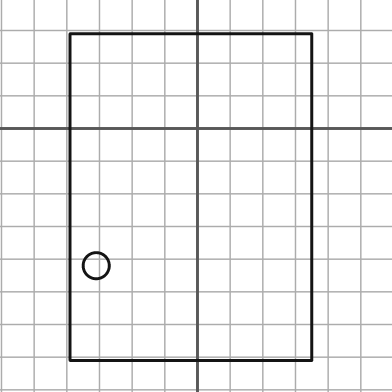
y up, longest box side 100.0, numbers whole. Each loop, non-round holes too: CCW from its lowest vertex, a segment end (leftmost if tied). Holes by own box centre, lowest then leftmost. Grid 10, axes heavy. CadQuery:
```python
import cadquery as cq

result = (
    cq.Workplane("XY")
    .moveTo(-39.0, -71.0)
    .lineTo(35.0, -71.0)
    .lineTo(35.0, 29.0)
    .lineTo(-39.0, 29.0)
    .close()
    .moveTo(-31.0, -42.0)
    .circle(4.0)
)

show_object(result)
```